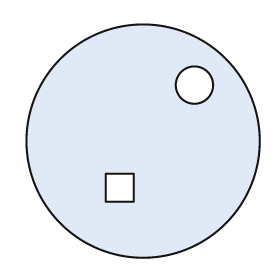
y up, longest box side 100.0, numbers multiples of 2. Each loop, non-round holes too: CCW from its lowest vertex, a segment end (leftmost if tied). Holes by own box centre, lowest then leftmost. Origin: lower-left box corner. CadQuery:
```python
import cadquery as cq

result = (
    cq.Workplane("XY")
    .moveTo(50.0, 50.0)
    .circle(50.0)
    .moveTo(34.0, 24.0)
    .lineTo(46.0, 24.0)
    .lineTo(46.0, 36.0)
    .lineTo(34.0, 36.0)
    .close()
    .moveTo(72.0, 74.0)
    .circle(8.0)
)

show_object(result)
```